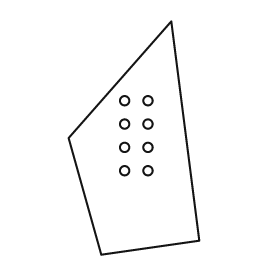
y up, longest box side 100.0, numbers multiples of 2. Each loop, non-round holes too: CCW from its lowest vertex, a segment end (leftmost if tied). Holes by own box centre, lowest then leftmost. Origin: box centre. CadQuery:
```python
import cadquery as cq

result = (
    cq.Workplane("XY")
    .moveTo(-14.0, -50.0)
    .lineTo(28.0, -44.0)
    .lineTo(16.0, 50.0)
    .lineTo(-28.0, 0.0)
    .close()
    .moveTo(-4.0, -14.0)
    .circle(2.0)
    .moveTo(6.0, -14.0)
    .circle(2.0)
    .moveTo(-4.0, -4.0)
    .circle(2.0)
    .moveTo(6.0, -4.0)
    .circle(2.0)
    .moveTo(-4.0, 6.0)
    .circle(2.0)
    .moveTo(6.0, 6.0)
    .circle(2.0)
    .moveTo(-4.0, 16.0)
    .circle(2.0)
    .moveTo(6.0, 16.0)
    .circle(2.0)
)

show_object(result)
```